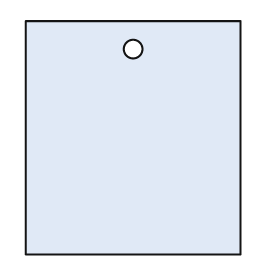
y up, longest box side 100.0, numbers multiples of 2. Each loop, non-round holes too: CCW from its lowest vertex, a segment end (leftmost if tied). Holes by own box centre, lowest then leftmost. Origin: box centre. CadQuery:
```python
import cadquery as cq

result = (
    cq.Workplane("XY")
    .moveTo(-46.0, -50.0)
    .lineTo(46.0, -50.0)
    .lineTo(46.0, 50.0)
    .lineTo(-46.0, 50.0)
    .close()
    .moveTo(0.0, 38.0)
    .circle(4.0)
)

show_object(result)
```